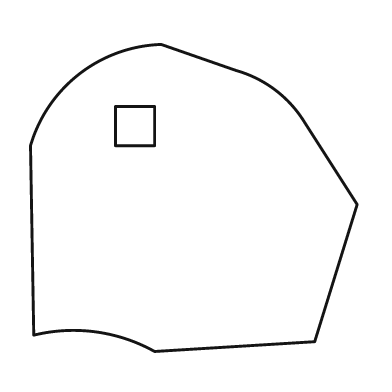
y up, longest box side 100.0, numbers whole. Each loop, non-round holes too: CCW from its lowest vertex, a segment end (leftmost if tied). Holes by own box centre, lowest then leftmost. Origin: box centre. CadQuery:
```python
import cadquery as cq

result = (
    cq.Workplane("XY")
    .moveTo(-12.0, -47.0)
    .lineTo(37.0, -44.0)
    .lineTo(50.0, -2.0)
    .lineTo(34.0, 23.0)
    .threePointArc((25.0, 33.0), (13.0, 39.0))
    .lineTo(-10.0, 47.0)
    .threePointArc((-35.0, 38.0), (-50.0, 16.0))
    .lineTo(-49.0, -42.0)
    .threePointArc((-30.0, -41.0), (-12.0, -47.0))
    .close()
    .moveTo(-24.0, 16.0)
    .lineTo(-12.0, 16.0)
    .lineTo(-12.0, 28.0)
    .lineTo(-24.0, 28.0)
    .close()
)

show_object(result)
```